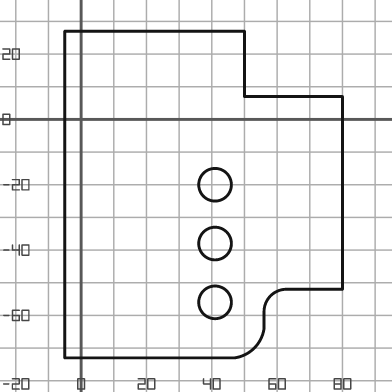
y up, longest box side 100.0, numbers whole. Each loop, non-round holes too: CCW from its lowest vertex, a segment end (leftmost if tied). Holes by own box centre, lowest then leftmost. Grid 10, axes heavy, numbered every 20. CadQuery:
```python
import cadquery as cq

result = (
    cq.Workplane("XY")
    .moveTo(-5.0, -73.0)
    .lineTo(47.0, -73.0)
    .threePointArc((53.0, -70.0), (56.0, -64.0))
    .lineTo(56.0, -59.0)
    .threePointArc((58.0, -54.0), (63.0, -52.0))
    .lineTo(80.0, -52.0)
    .lineTo(80.0, 7.0)
    .lineTo(50.0, 7.0)
    .lineTo(50.0, 27.0)
    .lineTo(-5.0, 27.0)
    .close()
    .moveTo(41.0, -56.0)
    .circle(5.0)
    .moveTo(41.0, -38.0)
    .circle(5.0)
    .moveTo(41.0, -20.0)
    .circle(5.0)
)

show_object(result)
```